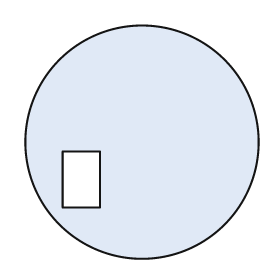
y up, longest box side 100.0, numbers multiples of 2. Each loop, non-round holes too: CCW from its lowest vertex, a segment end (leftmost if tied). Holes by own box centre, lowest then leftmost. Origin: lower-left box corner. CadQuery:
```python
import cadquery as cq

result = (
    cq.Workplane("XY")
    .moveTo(50.0, 50.0)
    .circle(50.0)
    .moveTo(16.0, 22.0)
    .lineTo(32.0, 22.0)
    .lineTo(32.0, 46.0)
    .lineTo(16.0, 46.0)
    .close()
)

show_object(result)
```